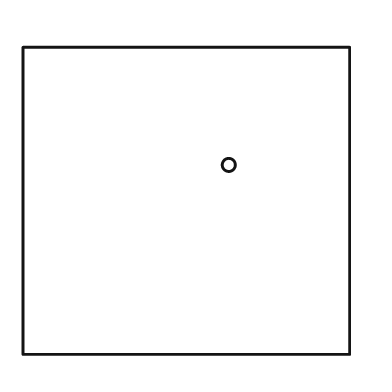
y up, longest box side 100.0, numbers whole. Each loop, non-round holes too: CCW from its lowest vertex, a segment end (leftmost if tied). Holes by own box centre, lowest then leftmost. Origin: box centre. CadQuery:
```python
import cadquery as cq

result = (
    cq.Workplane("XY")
    .moveTo(-50.0, -47.0)
    .lineTo(50.0, -47.0)
    .lineTo(50.0, 47.0)
    .lineTo(-50.0, 47.0)
    .close()
    .moveTo(13.0, 11.0)
    .circle(2.0)
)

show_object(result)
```